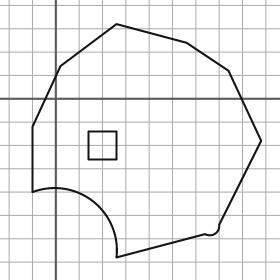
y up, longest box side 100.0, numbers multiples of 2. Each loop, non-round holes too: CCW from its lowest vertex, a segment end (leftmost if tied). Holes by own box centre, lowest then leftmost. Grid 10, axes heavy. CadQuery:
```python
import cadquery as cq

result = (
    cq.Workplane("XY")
    .moveTo(26.0, -68.0)
    .lineTo(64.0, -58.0)
    .threePointArc((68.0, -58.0), (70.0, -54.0))
    .lineTo(88.0, -18.0)
    .lineTo(74.0, 12.0)
    .lineTo(56.0, 24.0)
    .lineTo(26.0, 32.0)
    .lineTo(2.0, 14.0)
    .lineTo(-10.0, -12.0)
    .lineTo(-10.0, -40.0)
    .threePointArc((16.0, -44.0), (26.0, -68.0))
    .close()
    .moveTo(14.0, -26.0)
    .lineTo(26.0, -26.0)
    .lineTo(26.0, -14.0)
    .lineTo(14.0, -14.0)
    .close()
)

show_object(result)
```